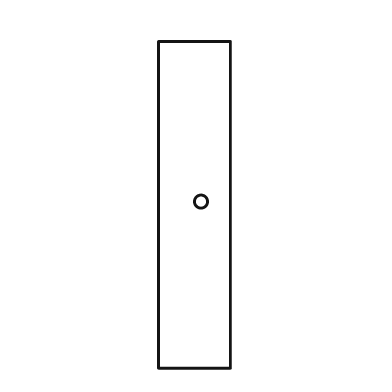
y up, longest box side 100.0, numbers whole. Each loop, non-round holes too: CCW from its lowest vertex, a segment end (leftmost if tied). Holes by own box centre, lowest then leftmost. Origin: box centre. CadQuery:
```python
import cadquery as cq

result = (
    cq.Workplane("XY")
    .moveTo(-11.0, -50.0)
    .lineTo(11.0, -50.0)
    .lineTo(11.0, 50.0)
    .lineTo(-11.0, 50.0)
    .close()
    .moveTo(2.0, 1.0)
    .circle(2.0)
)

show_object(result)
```